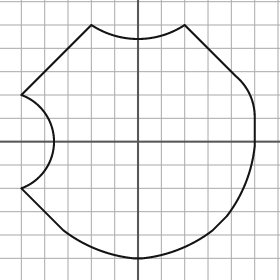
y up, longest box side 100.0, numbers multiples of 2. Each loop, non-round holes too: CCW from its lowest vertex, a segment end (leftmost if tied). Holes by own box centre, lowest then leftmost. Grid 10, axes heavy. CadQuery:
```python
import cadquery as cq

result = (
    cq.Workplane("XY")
    .moveTo(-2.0, -50.0)
    .lineTo(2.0, -50.0)
    .threePointArc((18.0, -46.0), (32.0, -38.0))
    .lineTo(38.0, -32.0)
    .threePointArc((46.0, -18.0), (50.0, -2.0))
    .lineTo(50.0, 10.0)
    .threePointArc((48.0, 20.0), (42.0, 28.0))
    .lineTo(20.0, 50.0)
    .threePointArc((0.0, 44.0), (-20.0, 50.0))
    .lineTo(-50.0, 20.0)
    .threePointArc((-36.0, 0.0), (-50.0, -20.0))
    .lineTo(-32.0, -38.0)
    .threePointArc((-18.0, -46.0), (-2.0, -50.0))
    .close()
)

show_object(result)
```